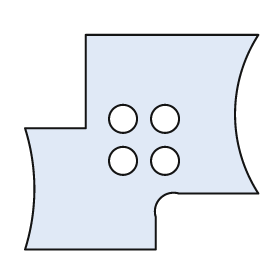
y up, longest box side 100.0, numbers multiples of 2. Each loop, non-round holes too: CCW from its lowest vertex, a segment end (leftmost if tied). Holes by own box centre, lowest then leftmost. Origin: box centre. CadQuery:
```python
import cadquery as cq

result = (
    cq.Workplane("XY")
    .moveTo(-50.0, -46.0)
    .lineTo(6.0, -46.0)
    .lineTo(6.0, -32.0)
    .threePointArc((8.0, -24.0), (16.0, -22.0))
    .lineTo(50.0, -22.0)
    .threePointArc((40.0, 12.0), (50.0, 46.0))
    .lineTo(-24.0, 46.0)
    .lineTo(-24.0, 6.0)
    .lineTo(-50.0, 6.0)
    .threePointArc((-46.0, -20.0), (-50.0, -46.0))
    .close()
    .moveTo(-8.0, -8.0)
    .circle(6.0)
    .moveTo(10.0, -8.0)
    .circle(6.0)
    .moveTo(-8.0, 10.0)
    .circle(6.0)
    .moveTo(10.0, 10.0)
    .circle(6.0)
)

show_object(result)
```